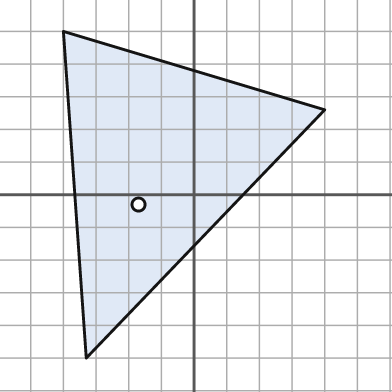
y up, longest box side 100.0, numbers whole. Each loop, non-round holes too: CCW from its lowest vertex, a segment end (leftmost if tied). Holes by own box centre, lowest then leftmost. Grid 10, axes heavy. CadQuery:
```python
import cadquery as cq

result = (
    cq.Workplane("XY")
    .moveTo(-33.0, -50.0)
    .lineTo(40.0, 26.0)
    .lineTo(-40.0, 50.0)
    .close()
    .moveTo(-17.0, -3.0)
    .circle(2.0)
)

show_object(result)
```